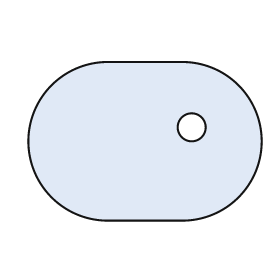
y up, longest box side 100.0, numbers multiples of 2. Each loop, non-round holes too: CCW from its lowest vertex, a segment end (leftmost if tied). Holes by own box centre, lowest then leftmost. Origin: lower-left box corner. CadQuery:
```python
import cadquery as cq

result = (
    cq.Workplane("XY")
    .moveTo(34.0, 0.0)
    .lineTo(66.0, 0.0)
    .threePointArc((100.0, 34.0), (66.0, 68.0))
    .lineTo(34.0, 68.0)
    .threePointArc((0.0, 34.0), (34.0, 0.0))
    .close()
    .moveTo(70.0, 40.0)
    .circle(6.0)
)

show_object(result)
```